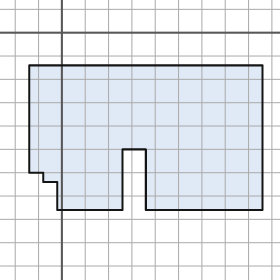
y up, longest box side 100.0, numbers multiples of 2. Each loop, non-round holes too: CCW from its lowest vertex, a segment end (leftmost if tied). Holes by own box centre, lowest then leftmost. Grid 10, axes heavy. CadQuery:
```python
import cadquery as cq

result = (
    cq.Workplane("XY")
    .moveTo(-2.0, -76.0)
    .lineTo(26.0, -76.0)
    .lineTo(26.0, -50.0)
    .lineTo(36.0, -50.0)
    .lineTo(36.0, -76.0)
    .lineTo(86.0, -76.0)
    .lineTo(86.0, -14.0)
    .lineTo(-14.0, -14.0)
    .lineTo(-14.0, -60.0)
    .lineTo(-8.0, -60.0)
    .lineTo(-8.0, -64.0)
    .lineTo(-2.0, -64.0)
    .close()
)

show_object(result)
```